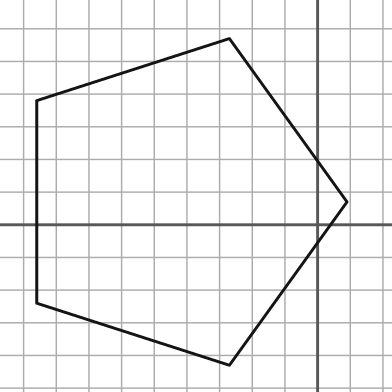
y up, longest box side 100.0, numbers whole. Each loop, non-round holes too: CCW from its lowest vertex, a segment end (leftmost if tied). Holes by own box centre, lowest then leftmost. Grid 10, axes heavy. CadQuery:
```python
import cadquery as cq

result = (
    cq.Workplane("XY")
    .moveTo(-27.0, -43.0)
    .lineTo(9.0, 7.0)
    .lineTo(-27.0, 57.0)
    .lineTo(-86.0, 38.0)
    .lineTo(-86.0, -24.0)
    .close()
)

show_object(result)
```